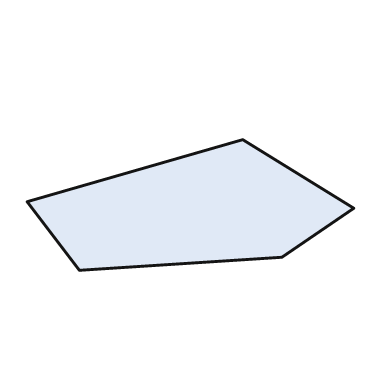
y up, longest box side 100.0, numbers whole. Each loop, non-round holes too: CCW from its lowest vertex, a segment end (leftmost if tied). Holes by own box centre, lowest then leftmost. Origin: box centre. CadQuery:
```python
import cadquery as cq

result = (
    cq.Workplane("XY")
    .moveTo(-34.0, -20.0)
    .lineTo(28.0, -16.0)
    .lineTo(50.0, -1.0)
    .lineTo(16.0, 20.0)
    .lineTo(-50.0, 1.0)
    .close()
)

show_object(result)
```